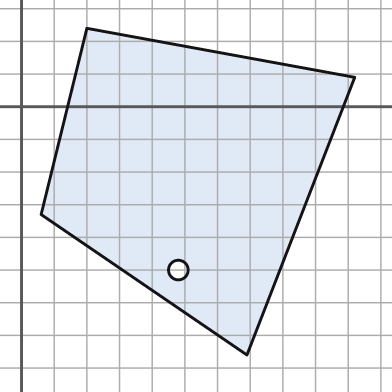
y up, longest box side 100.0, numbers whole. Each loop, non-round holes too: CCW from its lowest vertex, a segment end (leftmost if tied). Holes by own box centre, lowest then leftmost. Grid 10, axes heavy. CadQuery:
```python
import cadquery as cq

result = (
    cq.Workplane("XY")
    .moveTo(69.0, -76.0)
    .lineTo(102.0, 9.0)
    .lineTo(20.0, 24.0)
    .lineTo(6.0, -33.0)
    .close()
    .moveTo(48.0, -50.0)
    .circle(3.0)
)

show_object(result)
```